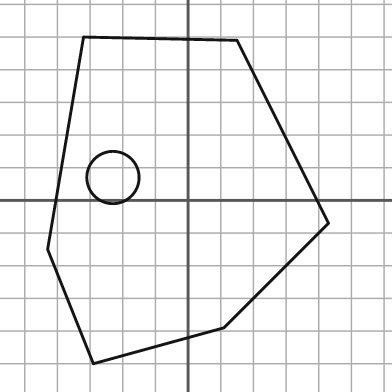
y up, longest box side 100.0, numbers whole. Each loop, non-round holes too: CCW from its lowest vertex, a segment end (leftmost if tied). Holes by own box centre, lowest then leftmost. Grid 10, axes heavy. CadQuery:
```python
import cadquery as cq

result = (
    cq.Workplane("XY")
    .moveTo(-29.0, -50.0)
    .lineTo(11.0, -39.0)
    .lineTo(43.0, -7.0)
    .lineTo(15.0, 49.0)
    .lineTo(-32.0, 50.0)
    .lineTo(-43.0, -15.0)
    .close()
    .moveTo(-23.0, 7.0)
    .circle(8.0)
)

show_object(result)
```